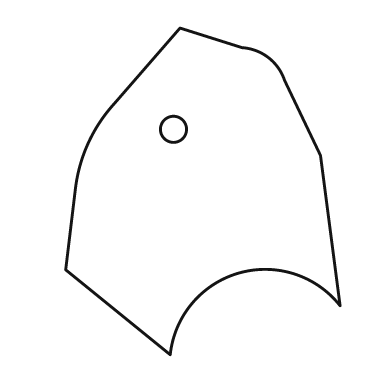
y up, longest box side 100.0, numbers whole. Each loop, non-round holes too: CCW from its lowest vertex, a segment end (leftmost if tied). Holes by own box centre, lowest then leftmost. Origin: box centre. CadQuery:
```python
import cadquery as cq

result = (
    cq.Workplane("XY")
    .moveTo(-10.0, -50.0)
    .threePointArc((11.0, -25.0), (42.0, -35.0))
    .lineTo(36.0, 11.0)
    .lineTo(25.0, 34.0)
    .threePointArc((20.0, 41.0), (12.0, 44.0))
    .lineTo(-7.0, 50.0)
    .lineTo(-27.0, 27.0)
    .threePointArc((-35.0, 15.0), (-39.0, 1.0))
    .lineTo(-42.0, -24.0)
    .close()
    .moveTo(-9.0, 19.0)
    .circle(4.0)
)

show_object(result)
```